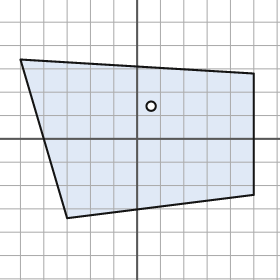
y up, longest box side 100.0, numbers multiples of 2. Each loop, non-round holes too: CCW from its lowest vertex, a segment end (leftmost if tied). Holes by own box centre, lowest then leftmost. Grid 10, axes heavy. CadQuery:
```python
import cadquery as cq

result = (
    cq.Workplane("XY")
    .moveTo(-30.0, -34.0)
    .lineTo(50.0, -24.0)
    .lineTo(50.0, 28.0)
    .lineTo(-50.0, 34.0)
    .close()
    .moveTo(6.0, 14.0)
    .circle(2.0)
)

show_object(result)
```